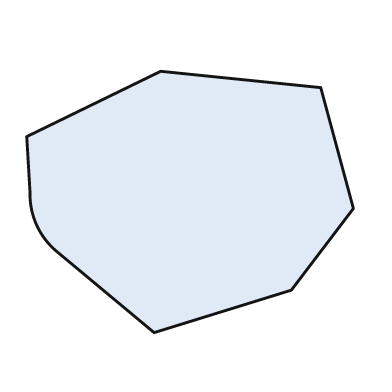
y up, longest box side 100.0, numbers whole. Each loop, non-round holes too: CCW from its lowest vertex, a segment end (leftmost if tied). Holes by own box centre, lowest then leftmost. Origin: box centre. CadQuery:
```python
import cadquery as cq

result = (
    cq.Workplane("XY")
    .moveTo(-11.0, -40.0)
    .lineTo(31.0, -27.0)
    .lineTo(50.0, -2.0)
    .lineTo(40.0, 35.0)
    .lineTo(-9.0, 40.0)
    .lineTo(-50.0, 20.0)
    .lineTo(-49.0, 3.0)
    .threePointArc((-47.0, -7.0), (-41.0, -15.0))
    .close()
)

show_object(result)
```